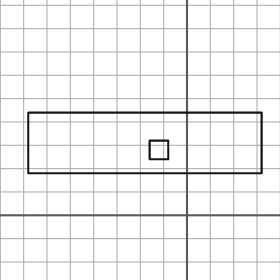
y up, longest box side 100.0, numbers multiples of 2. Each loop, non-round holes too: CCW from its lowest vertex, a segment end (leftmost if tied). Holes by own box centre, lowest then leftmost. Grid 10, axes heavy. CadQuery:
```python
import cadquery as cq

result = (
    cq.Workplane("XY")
    .moveTo(-68.0, 18.0)
    .lineTo(32.0, 18.0)
    .lineTo(32.0, 44.0)
    .lineTo(-68.0, 44.0)
    .close()
    .moveTo(-16.0, 24.0)
    .lineTo(-8.0, 24.0)
    .lineTo(-8.0, 32.0)
    .lineTo(-16.0, 32.0)
    .close()
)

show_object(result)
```